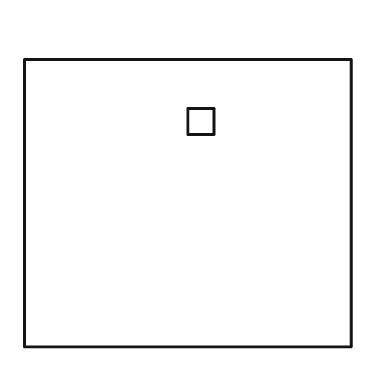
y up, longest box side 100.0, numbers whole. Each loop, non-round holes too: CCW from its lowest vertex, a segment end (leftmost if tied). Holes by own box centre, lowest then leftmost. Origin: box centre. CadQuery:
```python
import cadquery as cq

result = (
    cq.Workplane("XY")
    .moveTo(-50.0, -44.0)
    .lineTo(50.0, -44.0)
    .lineTo(50.0, 44.0)
    .lineTo(-50.0, 44.0)
    .close()
    .moveTo(0.0, 21.0)
    .lineTo(8.0, 21.0)
    .lineTo(8.0, 29.0)
    .lineTo(0.0, 29.0)
    .close()
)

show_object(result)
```